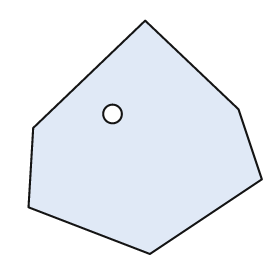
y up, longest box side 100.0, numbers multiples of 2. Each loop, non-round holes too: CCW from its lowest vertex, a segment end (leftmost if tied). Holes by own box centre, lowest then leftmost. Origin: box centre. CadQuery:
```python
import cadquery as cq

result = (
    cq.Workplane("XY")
    .moveTo(2.0, -50.0)
    .lineTo(50.0, -18.0)
    .lineTo(40.0, 12.0)
    .lineTo(0.0, 50.0)
    .lineTo(-48.0, 4.0)
    .lineTo(-50.0, -30.0)
    .close()
    .moveTo(-14.0, 10.0)
    .circle(4.0)
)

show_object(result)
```